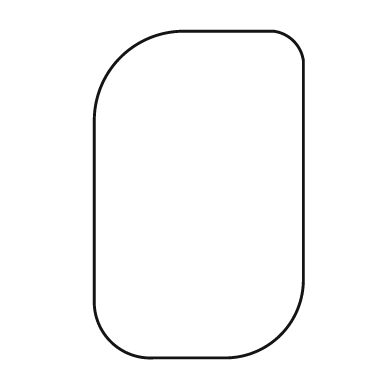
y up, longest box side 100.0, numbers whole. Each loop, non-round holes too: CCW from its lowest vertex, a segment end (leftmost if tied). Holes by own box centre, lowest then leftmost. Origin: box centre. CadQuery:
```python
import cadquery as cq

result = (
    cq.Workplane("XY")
    .moveTo(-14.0, -50.0)
    .lineTo(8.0, -50.0)
    .threePointArc((25.0, -43.0), (32.0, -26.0))
    .lineTo(32.0, 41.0)
    .threePointArc((29.0, 47.0), (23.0, 50.0))
    .lineTo(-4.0, 50.0)
    .threePointArc((-24.0, 42.0), (-32.0, 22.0))
    .lineTo(-32.0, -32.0)
    .threePointArc((-27.0, -45.0), (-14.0, -50.0))
    .close()
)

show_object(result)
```